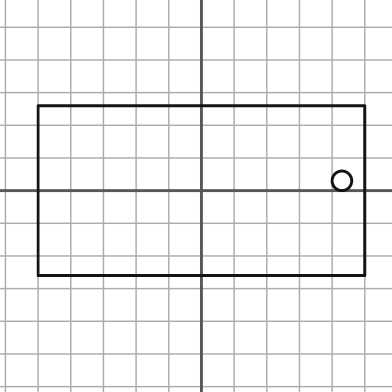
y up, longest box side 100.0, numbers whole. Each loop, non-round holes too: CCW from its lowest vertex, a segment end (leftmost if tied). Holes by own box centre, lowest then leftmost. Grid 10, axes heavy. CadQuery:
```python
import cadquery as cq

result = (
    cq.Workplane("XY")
    .moveTo(-50.0, -26.0)
    .lineTo(50.0, -26.0)
    .lineTo(50.0, 26.0)
    .lineTo(-50.0, 26.0)
    .close()
    .moveTo(43.0, 3.0)
    .circle(3.0)
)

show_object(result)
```